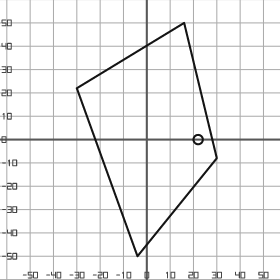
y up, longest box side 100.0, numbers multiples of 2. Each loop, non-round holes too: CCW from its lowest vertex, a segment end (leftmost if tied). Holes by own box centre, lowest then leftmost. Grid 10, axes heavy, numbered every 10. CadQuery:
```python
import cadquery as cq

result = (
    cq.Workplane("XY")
    .moveTo(-4.0, -50.0)
    .lineTo(30.0, -8.0)
    .lineTo(16.0, 50.0)
    .lineTo(-30.0, 22.0)
    .close()
    .moveTo(22.0, 0.0)
    .circle(2.0)
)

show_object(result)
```